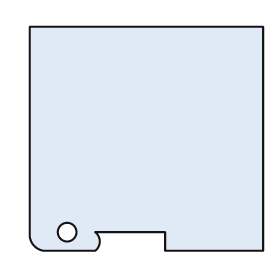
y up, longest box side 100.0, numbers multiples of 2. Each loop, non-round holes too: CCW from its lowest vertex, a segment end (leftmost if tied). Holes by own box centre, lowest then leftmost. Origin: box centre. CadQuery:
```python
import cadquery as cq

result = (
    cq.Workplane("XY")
    .moveTo(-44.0, -48.0)
    .lineTo(-22.0, -48.0)
    .threePointArc((-20.0, -44.0), (-22.0, -40.0))
    .lineTo(8.0, -40.0)
    .lineTo(8.0, -48.0)
    .lineTo(50.0, -48.0)
    .lineTo(50.0, 48.0)
    .lineTo(-50.0, 48.0)
    .lineTo(-50.0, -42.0)
    .threePointArc((-48.0, -46.0), (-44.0, -48.0))
    .close()
    .moveTo(-34.0, -40.0)
    .circle(4.0)
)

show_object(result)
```